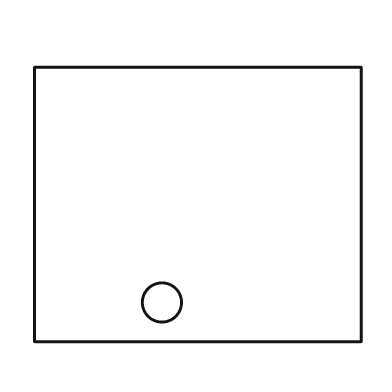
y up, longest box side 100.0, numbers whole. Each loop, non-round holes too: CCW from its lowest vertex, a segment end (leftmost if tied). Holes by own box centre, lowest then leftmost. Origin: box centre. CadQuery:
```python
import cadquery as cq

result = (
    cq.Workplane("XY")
    .moveTo(-50.0, -42.0)
    .lineTo(50.0, -42.0)
    .lineTo(50.0, 42.0)
    .lineTo(-50.0, 42.0)
    .close()
    .moveTo(-11.0, -30.0)
    .circle(6.0)
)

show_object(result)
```